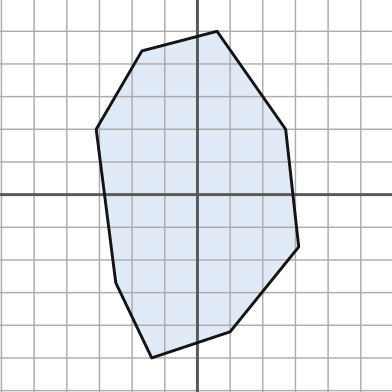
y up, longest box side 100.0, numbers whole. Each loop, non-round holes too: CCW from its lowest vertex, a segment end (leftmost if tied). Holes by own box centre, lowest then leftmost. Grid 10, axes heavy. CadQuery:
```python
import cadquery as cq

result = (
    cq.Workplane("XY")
    .moveTo(-14.0, -50.0)
    .lineTo(10.0, -42.0)
    .lineTo(31.0, -16.0)
    .lineTo(27.0, 20.0)
    .lineTo(6.0, 50.0)
    .lineTo(-17.0, 44.0)
    .lineTo(-31.0, 20.0)
    .lineTo(-25.0, -27.0)
    .close()
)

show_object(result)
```